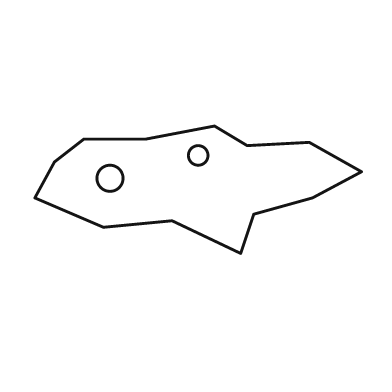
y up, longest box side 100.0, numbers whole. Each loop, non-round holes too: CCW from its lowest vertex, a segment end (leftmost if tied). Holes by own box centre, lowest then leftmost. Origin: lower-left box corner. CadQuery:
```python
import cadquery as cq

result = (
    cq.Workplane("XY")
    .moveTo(63.0, 0.0)
    .lineTo(67.0, 12.0)
    .lineTo(85.0, 17.0)
    .lineTo(100.0, 25.0)
    .lineTo(84.0, 34.0)
    .lineTo(65.0, 33.0)
    .lineTo(55.0, 39.0)
    .lineTo(34.0, 35.0)
    .lineTo(15.0, 35.0)
    .lineTo(6.0, 28.0)
    .lineTo(0.0, 17.0)
    .lineTo(21.0, 8.0)
    .lineTo(42.0, 10.0)
    .close()
    .moveTo(23.0, 23.0)
    .circle(4.0)
    .moveTo(50.0, 30.0)
    .circle(3.0)
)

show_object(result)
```